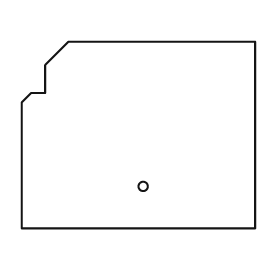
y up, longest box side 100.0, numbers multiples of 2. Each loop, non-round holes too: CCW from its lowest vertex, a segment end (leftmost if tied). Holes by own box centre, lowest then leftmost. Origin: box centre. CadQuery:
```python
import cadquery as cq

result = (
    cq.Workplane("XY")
    .moveTo(-50.0, -40.0)
    .lineTo(50.0, -40.0)
    .lineTo(50.0, 40.0)
    .lineTo(-30.0, 40.0)
    .lineTo(-40.0, 30.0)
    .lineTo(-40.0, 18.0)
    .lineTo(-46.0, 18.0)
    .lineTo(-50.0, 14.0)
    .close()
    .moveTo(2.0, -22.0)
    .circle(2.0)
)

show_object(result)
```